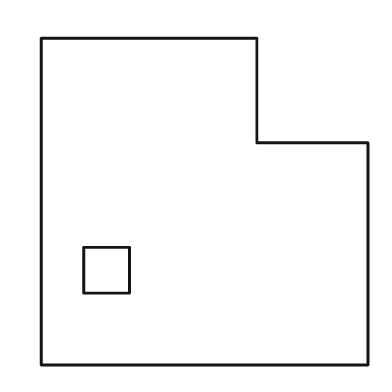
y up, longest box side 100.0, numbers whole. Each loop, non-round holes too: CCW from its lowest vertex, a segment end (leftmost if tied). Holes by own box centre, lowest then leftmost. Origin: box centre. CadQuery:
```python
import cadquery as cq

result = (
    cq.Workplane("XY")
    .moveTo(-50.0, -50.0)
    .lineTo(50.0, -50.0)
    .lineTo(50.0, 18.0)
    .lineTo(16.0, 18.0)
    .lineTo(16.0, 50.0)
    .lineTo(-50.0, 50.0)
    .close()
    .moveTo(-37.0, -28.0)
    .lineTo(-23.0, -28.0)
    .lineTo(-23.0, -14.0)
    .lineTo(-37.0, -14.0)
    .close()
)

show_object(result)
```